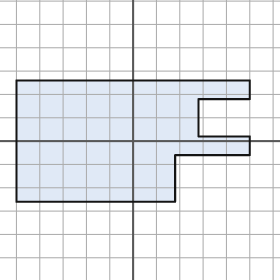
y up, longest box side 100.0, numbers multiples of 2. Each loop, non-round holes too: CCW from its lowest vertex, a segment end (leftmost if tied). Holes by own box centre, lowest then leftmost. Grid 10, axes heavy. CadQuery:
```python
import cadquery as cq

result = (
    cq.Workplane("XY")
    .moveTo(-50.0, -26.0)
    .lineTo(18.0, -26.0)
    .lineTo(18.0, -6.0)
    .lineTo(50.0, -6.0)
    .lineTo(50.0, 2.0)
    .lineTo(28.0, 2.0)
    .lineTo(28.0, 18.0)
    .lineTo(50.0, 18.0)
    .lineTo(50.0, 26.0)
    .lineTo(-50.0, 26.0)
    .close()
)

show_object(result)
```